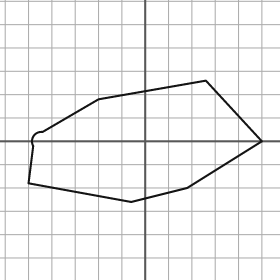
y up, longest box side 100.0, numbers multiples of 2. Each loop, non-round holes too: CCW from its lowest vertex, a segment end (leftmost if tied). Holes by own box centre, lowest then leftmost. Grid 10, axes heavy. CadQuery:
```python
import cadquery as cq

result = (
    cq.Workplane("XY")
    .moveTo(-6.0, -26.0)
    .lineTo(18.0, -20.0)
    .lineTo(50.0, 0.0)
    .lineTo(26.0, 26.0)
    .lineTo(-20.0, 18.0)
    .lineTo(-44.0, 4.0)
    .threePointArc((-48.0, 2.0), (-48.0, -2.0))
    .lineTo(-50.0, -18.0)
    .close()
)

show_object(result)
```